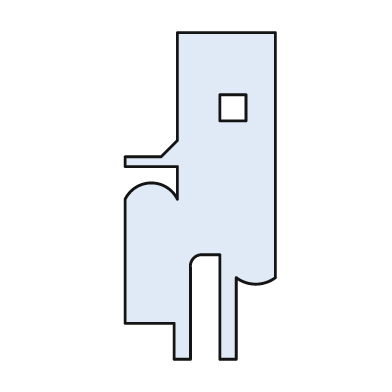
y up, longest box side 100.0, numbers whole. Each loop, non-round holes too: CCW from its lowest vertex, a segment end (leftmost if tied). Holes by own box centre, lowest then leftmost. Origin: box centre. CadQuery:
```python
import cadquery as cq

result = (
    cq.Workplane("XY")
    .moveTo(-8.0, -50.0)
    .lineTo(-3.0, -50.0)
    .lineTo(-3.0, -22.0)
    .threePointArc((-2.0, -19.0), (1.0, -18.0))
    .lineTo(6.0, -18.0)
    .lineTo(6.0, -50.0)
    .lineTo(11.0, -50.0)
    .lineTo(11.0, -25.0)
    .threePointArc((17.0, -27.0), (23.0, -25.0))
    .lineTo(23.0, 50.0)
    .lineTo(-7.0, 50.0)
    .lineTo(-7.0, 17.0)
    .lineTo(-12.0, 12.0)
    .lineTo(-23.0, 12.0)
    .lineTo(-23.0, 9.0)
    .lineTo(-7.0, 9.0)
    .lineTo(-7.0, -1.0)
    .threePointArc((-15.0, 4.0), (-23.0, -1.0))
    .lineTo(-23.0, -39.0)
    .lineTo(-8.0, -39.0)
    .close()
    .moveTo(6.0, 23.0)
    .lineTo(14.0, 23.0)
    .lineTo(14.0, 31.0)
    .lineTo(6.0, 31.0)
    .close()
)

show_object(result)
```